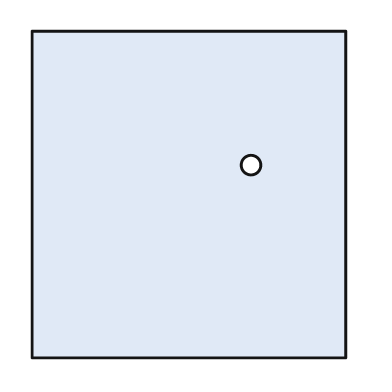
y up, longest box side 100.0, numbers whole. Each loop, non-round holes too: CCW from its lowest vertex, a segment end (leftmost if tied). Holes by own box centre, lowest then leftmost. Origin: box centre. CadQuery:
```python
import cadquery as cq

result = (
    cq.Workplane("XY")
    .moveTo(-48.0, -50.0)
    .lineTo(48.0, -50.0)
    .lineTo(48.0, 50.0)
    .lineTo(-48.0, 50.0)
    .close()
    .moveTo(19.0, 9.0)
    .circle(3.0)
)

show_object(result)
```